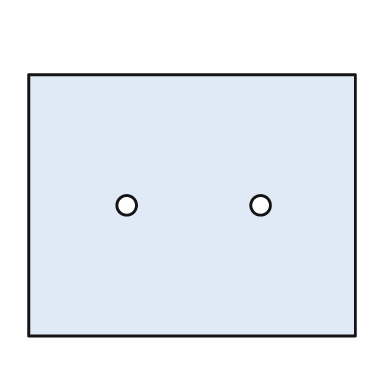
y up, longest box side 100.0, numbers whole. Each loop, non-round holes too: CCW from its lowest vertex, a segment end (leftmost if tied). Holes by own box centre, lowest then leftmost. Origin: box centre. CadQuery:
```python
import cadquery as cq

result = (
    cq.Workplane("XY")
    .moveTo(-50.0, -40.0)
    .lineTo(50.0, -40.0)
    .lineTo(50.0, 40.0)
    .lineTo(-50.0, 40.0)
    .close()
    .moveTo(-20.0, 0.0)
    .circle(3.0)
    .moveTo(21.0, 0.0)
    .circle(3.0)
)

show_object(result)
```